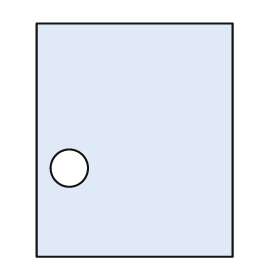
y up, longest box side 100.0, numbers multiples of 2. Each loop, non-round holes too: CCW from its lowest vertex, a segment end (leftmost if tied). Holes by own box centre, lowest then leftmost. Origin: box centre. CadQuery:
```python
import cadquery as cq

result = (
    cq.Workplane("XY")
    .moveTo(-42.0, -50.0)
    .lineTo(42.0, -50.0)
    .lineTo(42.0, 50.0)
    .lineTo(-42.0, 50.0)
    .close()
    .moveTo(-28.0, -12.0)
    .circle(8.0)
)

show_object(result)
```